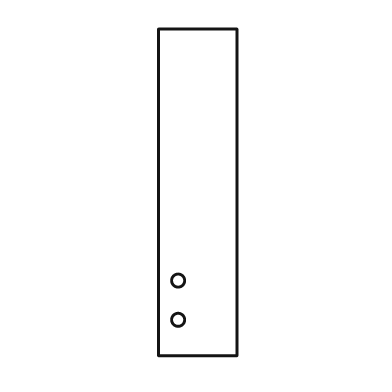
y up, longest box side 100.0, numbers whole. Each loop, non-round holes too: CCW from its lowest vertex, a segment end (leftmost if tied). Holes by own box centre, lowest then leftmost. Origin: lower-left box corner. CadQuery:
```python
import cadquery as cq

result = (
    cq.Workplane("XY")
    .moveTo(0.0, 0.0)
    .lineTo(24.0, 0.0)
    .lineTo(24.0, 100.0)
    .lineTo(0.0, 100.0)
    .close()
    .moveTo(6.0, 11.0)
    .circle(2.0)
    .moveTo(6.0, 23.0)
    .circle(2.0)
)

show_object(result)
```